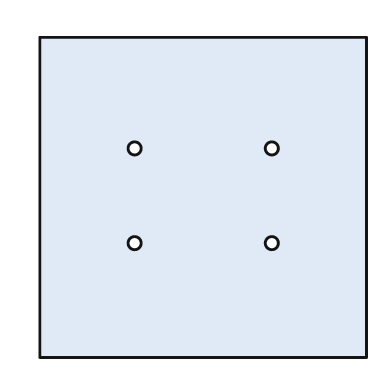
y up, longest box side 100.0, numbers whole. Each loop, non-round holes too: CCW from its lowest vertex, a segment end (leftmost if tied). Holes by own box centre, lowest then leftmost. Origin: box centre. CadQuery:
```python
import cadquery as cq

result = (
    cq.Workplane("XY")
    .moveTo(-50.0, -49.0)
    .lineTo(50.0, -49.0)
    .lineTo(50.0, 49.0)
    .lineTo(-50.0, 49.0)
    .close()
    .moveTo(-21.0, -14.0)
    .circle(2.0)
    .moveTo(21.0, -14.0)
    .circle(2.0)
    .moveTo(-21.0, 15.0)
    .circle(2.0)
    .moveTo(21.0, 15.0)
    .circle(2.0)
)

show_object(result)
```